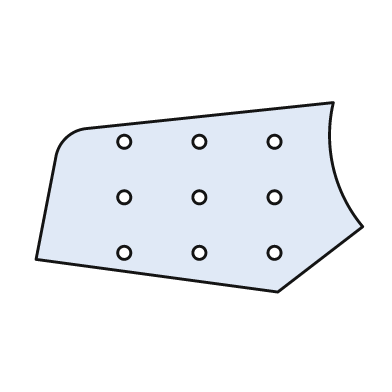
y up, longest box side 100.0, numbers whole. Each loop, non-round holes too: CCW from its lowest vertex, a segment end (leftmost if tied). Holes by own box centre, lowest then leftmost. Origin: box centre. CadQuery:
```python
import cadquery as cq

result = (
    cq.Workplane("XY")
    .moveTo(24.0, -29.0)
    .lineTo(50.0, -9.0)
    .threePointArc((41.0, 9.0), (41.0, 29.0))
    .lineTo(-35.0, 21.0)
    .threePointArc((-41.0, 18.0), (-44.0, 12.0))
    .lineTo(-50.0, -19.0)
    .close()
    .moveTo(-23.0, -17.0)
    .circle(2.0)
    .moveTo(0.0, -17.0)
    .circle(2.0)
    .moveTo(23.0, -17.0)
    .circle(2.0)
    .moveTo(-23.0, 0.0)
    .circle(2.0)
    .moveTo(0.0, 0.0)
    .circle(2.0)
    .moveTo(23.0, 0.0)
    .circle(2.0)
    .moveTo(-23.0, 17.0)
    .circle(2.0)
    .moveTo(0.0, 17.0)
    .circle(2.0)
    .moveTo(23.0, 17.0)
    .circle(2.0)
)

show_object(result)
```